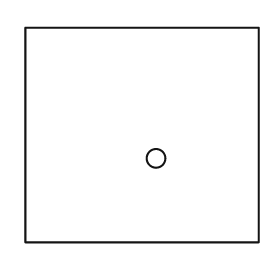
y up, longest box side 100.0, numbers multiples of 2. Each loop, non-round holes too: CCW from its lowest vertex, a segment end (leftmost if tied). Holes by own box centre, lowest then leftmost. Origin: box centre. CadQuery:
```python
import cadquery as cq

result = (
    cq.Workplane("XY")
    .moveTo(-50.0, -46.0)
    .lineTo(50.0, -46.0)
    .lineTo(50.0, 46.0)
    .lineTo(-50.0, 46.0)
    .close()
    .moveTo(6.0, -10.0)
    .circle(4.0)
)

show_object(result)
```